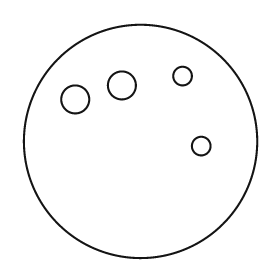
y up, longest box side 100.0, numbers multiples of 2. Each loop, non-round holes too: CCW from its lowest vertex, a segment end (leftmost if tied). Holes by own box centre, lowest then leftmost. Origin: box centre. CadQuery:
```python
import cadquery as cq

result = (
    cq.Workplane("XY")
    .moveTo(0.0, 0.0)
    .circle(50.0)
    .moveTo(26.0, -2.0)
    .circle(4.0)
    .moveTo(-28.0, 18.0)
    .circle(6.0)
    .moveTo(-8.0, 24.0)
    .circle(6.0)
    .moveTo(18.0, 28.0)
    .circle(4.0)
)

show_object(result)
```